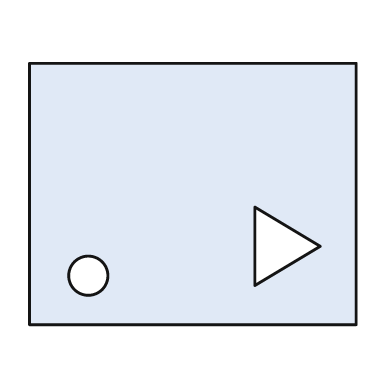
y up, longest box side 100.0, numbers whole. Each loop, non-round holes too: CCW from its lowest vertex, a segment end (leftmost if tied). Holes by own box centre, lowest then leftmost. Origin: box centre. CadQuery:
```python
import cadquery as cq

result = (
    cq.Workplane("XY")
    .moveTo(-50.0, -40.0)
    .lineTo(50.0, -40.0)
    .lineTo(50.0, 40.0)
    .lineTo(-50.0, 40.0)
    .close()
    .moveTo(-32.0, -25.0)
    .circle(6.0)
    .moveTo(19.0, -28.0)
    .lineTo(39.0, -16.0)
    .lineTo(19.0, -4.0)
    .close()
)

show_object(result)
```